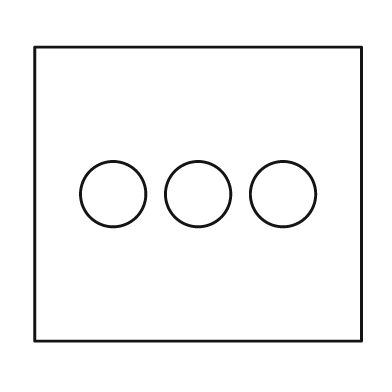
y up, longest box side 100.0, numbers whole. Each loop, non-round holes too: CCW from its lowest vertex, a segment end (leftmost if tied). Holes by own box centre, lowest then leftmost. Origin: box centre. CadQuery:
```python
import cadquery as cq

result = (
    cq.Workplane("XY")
    .moveTo(-50.0, -45.0)
    .lineTo(50.0, -45.0)
    .lineTo(50.0, 45.0)
    .lineTo(-50.0, 45.0)
    .close()
    .moveTo(-26.0, 0.0)
    .circle(10.0)
    .moveTo(0.0, 0.0)
    .circle(10.0)
    .moveTo(26.0, 0.0)
    .circle(10.0)
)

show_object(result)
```